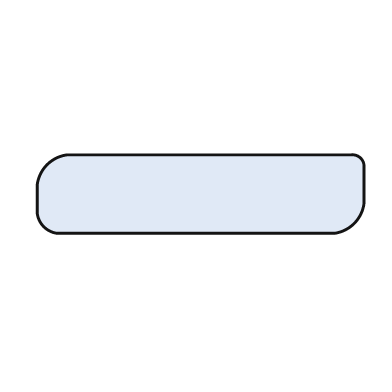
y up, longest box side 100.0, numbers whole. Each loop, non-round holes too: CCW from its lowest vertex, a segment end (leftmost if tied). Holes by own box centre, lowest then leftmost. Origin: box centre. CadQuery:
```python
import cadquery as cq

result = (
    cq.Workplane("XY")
    .moveTo(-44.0, -12.0)
    .lineTo(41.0, -12.0)
    .threePointArc((47.0, -9.0), (50.0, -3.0))
    .lineTo(50.0, 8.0)
    .threePointArc((49.0, 11.0), (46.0, 12.0))
    .lineTo(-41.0, 12.0)
    .threePointArc((-47.0, 9.0), (-50.0, 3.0))
    .lineTo(-50.0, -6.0)
    .threePointArc((-48.0, -10.0), (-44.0, -12.0))
    .close()
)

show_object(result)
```